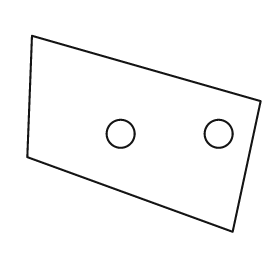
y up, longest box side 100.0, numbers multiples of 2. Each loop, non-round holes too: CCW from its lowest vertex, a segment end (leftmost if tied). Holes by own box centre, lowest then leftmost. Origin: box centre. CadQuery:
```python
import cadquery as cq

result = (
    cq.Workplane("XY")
    .moveTo(38.0, -42.0)
    .lineTo(50.0, 14.0)
    .lineTo(-48.0, 42.0)
    .lineTo(-50.0, -10.0)
    .close()
    .moveTo(-10.0, 0.0)
    .circle(6.0)
    .moveTo(32.0, 0.0)
    .circle(6.0)
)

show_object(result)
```